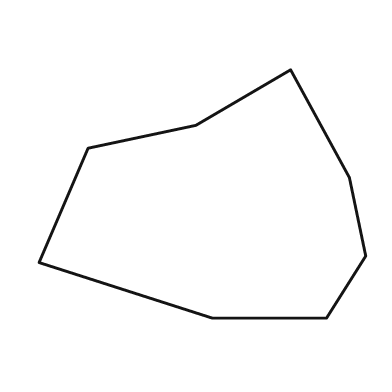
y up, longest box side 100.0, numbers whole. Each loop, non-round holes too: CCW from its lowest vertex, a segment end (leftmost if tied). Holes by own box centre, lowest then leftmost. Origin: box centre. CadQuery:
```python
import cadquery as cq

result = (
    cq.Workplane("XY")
    .moveTo(3.0, -38.0)
    .lineTo(38.0, -38.0)
    .lineTo(50.0, -19.0)
    .lineTo(45.0, 5.0)
    .lineTo(27.0, 38.0)
    .lineTo(-2.0, 21.0)
    .lineTo(-35.0, 14.0)
    .lineTo(-50.0, -21.0)
    .close()
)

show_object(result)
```